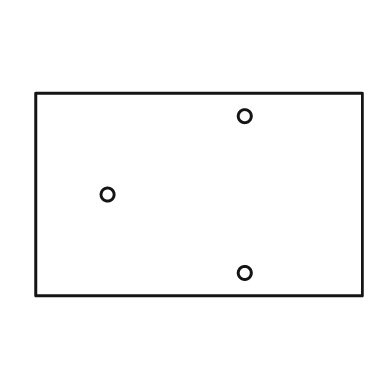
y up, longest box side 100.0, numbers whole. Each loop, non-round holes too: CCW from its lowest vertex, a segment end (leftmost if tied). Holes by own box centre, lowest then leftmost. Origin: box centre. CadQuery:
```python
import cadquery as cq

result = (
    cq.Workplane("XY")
    .moveTo(-50.0, -31.0)
    .lineTo(50.0, -31.0)
    .lineTo(50.0, 31.0)
    .lineTo(-50.0, 31.0)
    .close()
    .moveTo(14.0, -24.0)
    .circle(2.0)
    .moveTo(-28.0, 0.0)
    .circle(2.0)
    .moveTo(14.0, 24.0)
    .circle(2.0)
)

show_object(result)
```